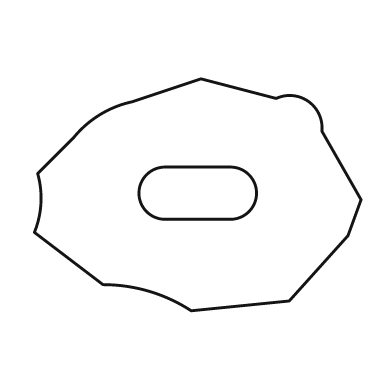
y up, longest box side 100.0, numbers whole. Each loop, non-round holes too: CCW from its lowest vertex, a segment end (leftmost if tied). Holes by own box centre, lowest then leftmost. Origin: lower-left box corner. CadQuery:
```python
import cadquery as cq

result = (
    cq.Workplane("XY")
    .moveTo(48.0, 0.0)
    .lineTo(78.0, 3.0)
    .lineTo(96.0, 23.0)
    .lineTo(100.0, 34.0)
    .lineTo(88.0, 55.0)
    .threePointArc((84.0, 64.0), (74.0, 65.0))
    .lineTo(51.0, 71.0)
    .lineTo(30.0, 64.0)
    .threePointArc((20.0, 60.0), (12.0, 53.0))
    .lineTo(1.0, 42.0)
    .threePointArc((2.0, 33.0), (0.0, 24.0))
    .lineTo(21.0, 8.0)
    .threePointArc((35.0, 6.0), (48.0, 0.0))
    .close()
    .moveTo(40.0, 28.0)
    .lineTo(60.0, 28.0)
    .threePointArc((68.0, 36.0), (60.0, 44.0))
    .lineTo(40.0, 44.0)
    .threePointArc((32.0, 36.0), (40.0, 28.0))
    .close()
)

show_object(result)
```